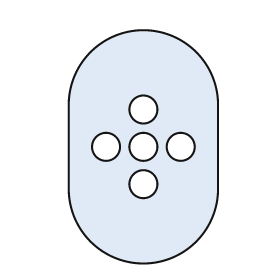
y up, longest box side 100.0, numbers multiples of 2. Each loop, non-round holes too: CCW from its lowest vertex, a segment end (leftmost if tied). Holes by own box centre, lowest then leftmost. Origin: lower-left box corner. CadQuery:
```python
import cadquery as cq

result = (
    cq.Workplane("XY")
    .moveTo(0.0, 32.0)
    .threePointArc((32.0, 0.0), (64.0, 32.0))
    .lineTo(64.0, 68.0)
    .threePointArc((32.0, 100.0), (0.0, 68.0))
    .close()
    .moveTo(32.0, 34.0)
    .circle(6.0)
    .moveTo(16.0, 50.0)
    .circle(6.0)
    .moveTo(32.0, 50.0)
    .circle(6.0)
    .moveTo(48.0, 50.0)
    .circle(6.0)
    .moveTo(32.0, 66.0)
    .circle(6.0)
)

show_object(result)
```